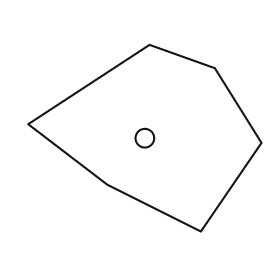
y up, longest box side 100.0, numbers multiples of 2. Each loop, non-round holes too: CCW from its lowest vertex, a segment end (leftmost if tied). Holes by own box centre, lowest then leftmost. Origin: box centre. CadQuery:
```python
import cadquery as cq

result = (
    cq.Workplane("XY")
    .moveTo(24.0, -40.0)
    .lineTo(50.0, -2.0)
    .lineTo(30.0, 30.0)
    .lineTo(2.0, 40.0)
    .lineTo(-50.0, 6.0)
    .lineTo(-16.0, -20.0)
    .close()
    .moveTo(0.0, 0.0)
    .circle(4.0)
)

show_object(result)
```